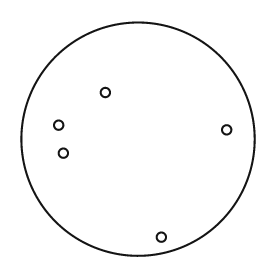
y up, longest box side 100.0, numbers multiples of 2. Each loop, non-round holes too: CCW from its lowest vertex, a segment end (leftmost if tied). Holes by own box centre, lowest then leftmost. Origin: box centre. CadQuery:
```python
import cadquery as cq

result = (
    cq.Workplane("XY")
    .moveTo(0.0, 0.0)
    .circle(50.0)
    .moveTo(10.0, -42.0)
    .circle(2.0)
    .moveTo(-32.0, -6.0)
    .circle(2.0)
    .moveTo(38.0, 4.0)
    .circle(2.0)
    .moveTo(-34.0, 6.0)
    .circle(2.0)
    .moveTo(-14.0, 20.0)
    .circle(2.0)
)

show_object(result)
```